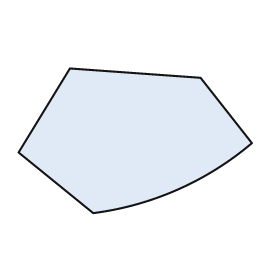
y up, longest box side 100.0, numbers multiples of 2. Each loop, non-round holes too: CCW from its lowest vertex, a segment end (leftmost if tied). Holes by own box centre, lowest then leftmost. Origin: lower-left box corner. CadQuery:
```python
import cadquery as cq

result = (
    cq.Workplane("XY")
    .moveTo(32.0, 0.0)
    .threePointArc((68.0, 10.0), (100.0, 30.0))
    .lineTo(78.0, 58.0)
    .lineTo(22.0, 62.0)
    .lineTo(0.0, 26.0)
    .close()
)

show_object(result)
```